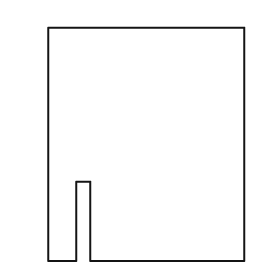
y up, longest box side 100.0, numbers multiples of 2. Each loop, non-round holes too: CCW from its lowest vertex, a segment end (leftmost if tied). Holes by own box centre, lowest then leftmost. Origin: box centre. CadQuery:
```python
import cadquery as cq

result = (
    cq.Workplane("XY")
    .moveTo(-42.0, -50.0)
    .lineTo(-30.0, -50.0)
    .lineTo(-30.0, -16.0)
    .lineTo(-24.0, -16.0)
    .lineTo(-24.0, -50.0)
    .lineTo(42.0, -50.0)
    .lineTo(42.0, 50.0)
    .lineTo(-42.0, 50.0)
    .close()
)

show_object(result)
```